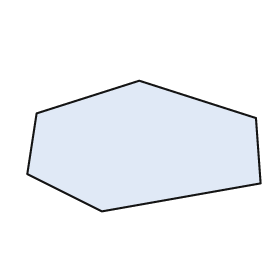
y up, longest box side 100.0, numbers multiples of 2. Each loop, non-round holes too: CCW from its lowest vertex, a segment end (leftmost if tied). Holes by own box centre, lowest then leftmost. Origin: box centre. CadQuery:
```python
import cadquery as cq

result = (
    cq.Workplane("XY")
    .moveTo(-18.0, -28.0)
    .lineTo(50.0, -16.0)
    .lineTo(48.0, 12.0)
    .lineTo(-2.0, 28.0)
    .lineTo(-46.0, 14.0)
    .lineTo(-50.0, -12.0)
    .close()
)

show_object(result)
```